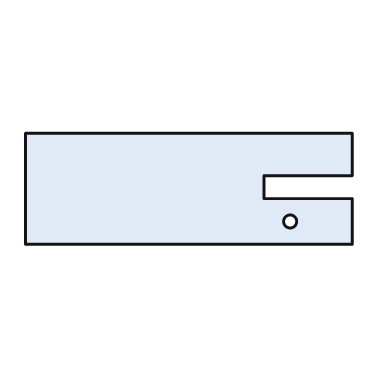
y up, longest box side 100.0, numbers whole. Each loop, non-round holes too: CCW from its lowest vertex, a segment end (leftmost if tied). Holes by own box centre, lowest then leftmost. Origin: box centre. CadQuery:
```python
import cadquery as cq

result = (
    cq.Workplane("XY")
    .moveTo(-50.0, -17.0)
    .lineTo(50.0, -17.0)
    .lineTo(50.0, -3.0)
    .lineTo(23.0, -3.0)
    .lineTo(23.0, 4.0)
    .lineTo(50.0, 4.0)
    .lineTo(50.0, 17.0)
    .lineTo(-50.0, 17.0)
    .close()
    .moveTo(31.0, -10.0)
    .circle(2.0)
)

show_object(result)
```